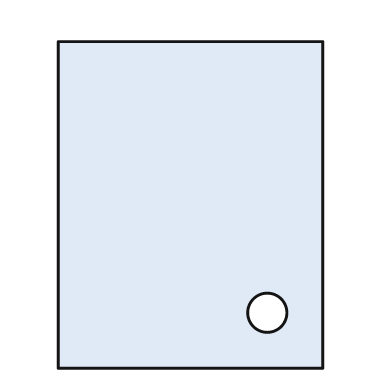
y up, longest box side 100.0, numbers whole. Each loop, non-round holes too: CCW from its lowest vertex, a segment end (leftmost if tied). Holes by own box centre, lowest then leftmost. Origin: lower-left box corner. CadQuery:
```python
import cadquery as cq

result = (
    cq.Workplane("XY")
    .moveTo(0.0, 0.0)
    .lineTo(81.0, 0.0)
    .lineTo(81.0, 100.0)
    .lineTo(0.0, 100.0)
    .close()
    .moveTo(64.0, 17.0)
    .circle(6.0)
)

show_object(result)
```